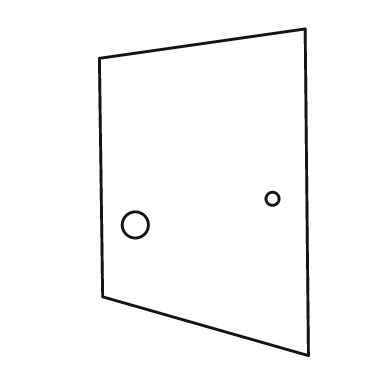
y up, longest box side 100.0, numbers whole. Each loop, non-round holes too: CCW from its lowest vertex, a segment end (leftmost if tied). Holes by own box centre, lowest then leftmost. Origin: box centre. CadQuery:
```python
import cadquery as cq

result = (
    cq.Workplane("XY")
    .moveTo(32.0, -50.0)
    .lineTo(31.0, 50.0)
    .lineTo(-32.0, 41.0)
    .lineTo(-31.0, -32.0)
    .close()
    .moveTo(-21.0, -10.0)
    .circle(4.0)
    .moveTo(21.0, -2.0)
    .circle(2.0)
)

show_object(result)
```